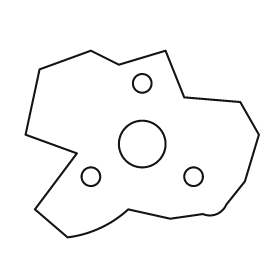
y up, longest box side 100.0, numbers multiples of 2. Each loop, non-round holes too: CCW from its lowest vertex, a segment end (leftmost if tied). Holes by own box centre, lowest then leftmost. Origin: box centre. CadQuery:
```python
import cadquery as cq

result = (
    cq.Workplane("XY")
    .moveTo(-32.0, -40.0)
    .threePointArc((-18.0, -36.0), (-6.0, -28.0))
    .lineTo(12.0, -32.0)
    .lineTo(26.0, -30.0)
    .threePointArc((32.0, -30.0), (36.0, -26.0))
    .lineTo(44.0, -16.0)
    .lineTo(50.0, 4.0)
    .lineTo(42.0, 18.0)
    .lineTo(18.0, 20.0)
    .lineTo(10.0, 40.0)
    .lineTo(-10.0, 34.0)
    .lineTo(-22.0, 40.0)
    .lineTo(-44.0, 32.0)
    .lineTo(-50.0, 4.0)
    .lineTo(-28.0, -4.0)
    .lineTo(-46.0, -28.0)
    .close()
    .moveTo(-22.0, -14.0)
    .circle(4.0)
    .moveTo(22.0, -14.0)
    .circle(4.0)
    .moveTo(0.0, 0.0)
    .circle(10.0)
    .moveTo(0.0, 26.0)
    .circle(4.0)
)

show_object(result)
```